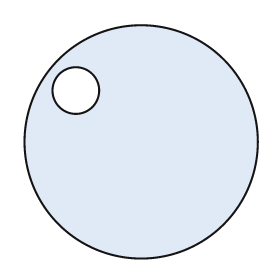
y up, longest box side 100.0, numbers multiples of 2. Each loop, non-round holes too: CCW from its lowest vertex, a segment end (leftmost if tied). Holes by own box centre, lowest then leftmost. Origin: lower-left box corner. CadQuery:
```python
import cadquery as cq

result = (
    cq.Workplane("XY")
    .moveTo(50.0, 50.0)
    .circle(50.0)
    .moveTo(22.0, 72.0)
    .circle(10.0)
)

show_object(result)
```